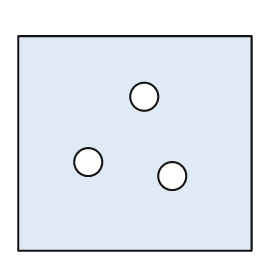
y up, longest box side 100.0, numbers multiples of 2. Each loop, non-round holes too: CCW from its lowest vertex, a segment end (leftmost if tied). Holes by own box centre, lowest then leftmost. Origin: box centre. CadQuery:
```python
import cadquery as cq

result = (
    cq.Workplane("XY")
    .moveTo(-50.0, -46.0)
    .lineTo(50.0, -46.0)
    .lineTo(50.0, 46.0)
    .lineTo(-50.0, 46.0)
    .close()
    .moveTo(16.0, -14.0)
    .circle(6.0)
    .moveTo(-20.0, -8.0)
    .circle(6.0)
    .moveTo(4.0, 20.0)
    .circle(6.0)
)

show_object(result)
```